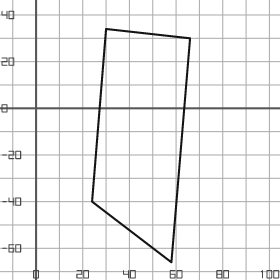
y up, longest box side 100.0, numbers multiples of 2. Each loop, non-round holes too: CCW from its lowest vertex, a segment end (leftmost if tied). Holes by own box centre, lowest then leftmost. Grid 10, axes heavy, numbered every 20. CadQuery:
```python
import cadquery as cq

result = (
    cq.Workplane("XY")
    .moveTo(58.0, -66.0)
    .lineTo(66.0, 30.0)
    .lineTo(30.0, 34.0)
    .lineTo(24.0, -40.0)
    .close()
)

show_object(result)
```